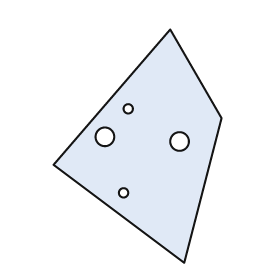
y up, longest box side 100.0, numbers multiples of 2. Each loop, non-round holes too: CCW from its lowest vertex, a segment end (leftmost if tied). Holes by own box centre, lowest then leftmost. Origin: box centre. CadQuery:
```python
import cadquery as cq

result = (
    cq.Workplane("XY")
    .moveTo(20.0, -50.0)
    .lineTo(36.0, 12.0)
    .lineTo(14.0, 50.0)
    .lineTo(-36.0, -8.0)
    .close()
    .moveTo(-6.0, -20.0)
    .circle(2.0)
    .moveTo(18.0, 2.0)
    .circle(4.0)
    .moveTo(-14.0, 4.0)
    .circle(4.0)
    .moveTo(-4.0, 16.0)
    .circle(2.0)
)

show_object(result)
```